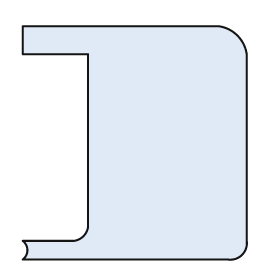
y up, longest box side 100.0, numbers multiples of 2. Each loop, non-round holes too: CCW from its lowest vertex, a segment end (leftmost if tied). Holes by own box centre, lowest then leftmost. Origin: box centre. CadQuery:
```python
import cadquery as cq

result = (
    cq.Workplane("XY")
    .moveTo(-48.0, -50.0)
    .lineTo(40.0, -50.0)
    .threePointArc((46.0, -48.0), (48.0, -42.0))
    .lineTo(48.0, 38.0)
    .threePointArc((44.0, 46.0), (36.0, 50.0))
    .lineTo(-48.0, 50.0)
    .lineTo(-48.0, 38.0)
    .lineTo(-20.0, 38.0)
    .lineTo(-20.0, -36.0)
    .threePointArc((-22.0, -40.0), (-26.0, -42.0))
    .lineTo(-48.0, -42.0)
    .threePointArc((-46.0, -46.0), (-48.0, -50.0))
    .close()
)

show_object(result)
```